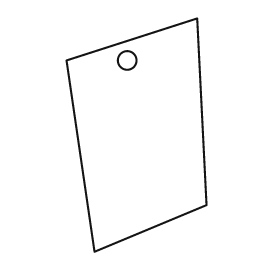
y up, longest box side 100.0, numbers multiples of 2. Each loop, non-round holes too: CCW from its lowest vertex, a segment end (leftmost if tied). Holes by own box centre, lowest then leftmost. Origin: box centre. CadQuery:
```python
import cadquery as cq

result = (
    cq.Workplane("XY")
    .moveTo(-18.0, -50.0)
    .lineTo(30.0, -30.0)
    .lineTo(26.0, 50.0)
    .lineTo(-30.0, 32.0)
    .close()
    .moveTo(-4.0, 32.0)
    .circle(4.0)
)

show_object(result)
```